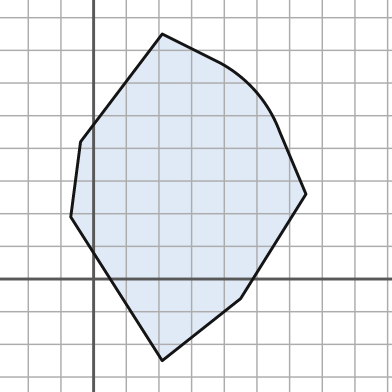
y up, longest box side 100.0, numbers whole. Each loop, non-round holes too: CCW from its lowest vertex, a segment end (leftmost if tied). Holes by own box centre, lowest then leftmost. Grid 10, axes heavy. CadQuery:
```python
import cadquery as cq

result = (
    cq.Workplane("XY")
    .moveTo(21.0, -25.0)
    .lineTo(45.0, -6.0)
    .lineTo(65.0, 26.0)
    .lineTo(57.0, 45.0)
    .threePointArc((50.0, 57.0), (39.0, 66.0))
    .lineTo(21.0, 75.0)
    .lineTo(-4.0, 42.0)
    .lineTo(-7.0, 19.0)
    .close()
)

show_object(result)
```